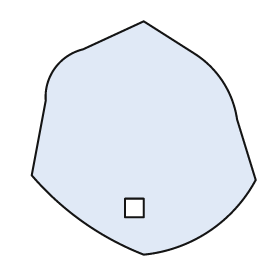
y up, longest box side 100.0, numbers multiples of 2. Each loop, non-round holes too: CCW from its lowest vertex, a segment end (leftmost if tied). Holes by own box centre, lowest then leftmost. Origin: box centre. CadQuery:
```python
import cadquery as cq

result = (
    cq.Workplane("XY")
    .moveTo(0.0, -50.0)
    .threePointArc((28.0, -40.0), (48.0, -18.0))
    .lineTo(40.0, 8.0)
    .threePointArc((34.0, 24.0), (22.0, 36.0))
    .lineTo(0.0, 50.0)
    .lineTo(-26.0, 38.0)
    .threePointArc((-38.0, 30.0), (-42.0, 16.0))
    .lineTo(-48.0, -16.0)
    .threePointArc((-26.0, -36.0), (0.0, -50.0))
    .close()
    .moveTo(-8.0, -34.0)
    .lineTo(0.0, -34.0)
    .lineTo(0.0, -26.0)
    .lineTo(-8.0, -26.0)
    .close()
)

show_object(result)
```